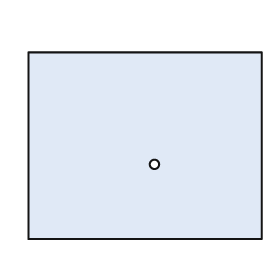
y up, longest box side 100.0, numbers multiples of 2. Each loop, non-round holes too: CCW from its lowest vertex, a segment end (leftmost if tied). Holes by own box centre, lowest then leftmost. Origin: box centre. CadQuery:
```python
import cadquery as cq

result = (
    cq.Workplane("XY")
    .moveTo(-50.0, -40.0)
    .lineTo(50.0, -40.0)
    .lineTo(50.0, 40.0)
    .lineTo(-50.0, 40.0)
    .close()
    .moveTo(4.0, -8.0)
    .circle(2.0)
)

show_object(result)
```